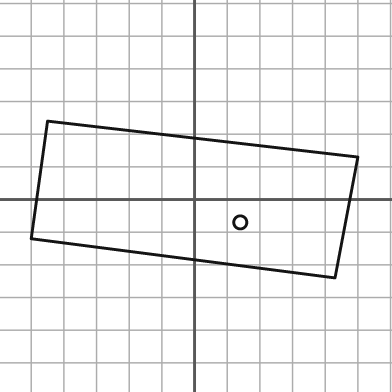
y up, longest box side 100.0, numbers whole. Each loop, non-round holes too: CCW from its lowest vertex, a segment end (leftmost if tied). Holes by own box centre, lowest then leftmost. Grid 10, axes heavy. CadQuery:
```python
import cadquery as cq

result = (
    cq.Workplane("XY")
    .moveTo(43.0, -24.0)
    .lineTo(50.0, 13.0)
    .lineTo(-45.0, 24.0)
    .lineTo(-50.0, -12.0)
    .close()
    .moveTo(14.0, -7.0)
    .circle(2.0)
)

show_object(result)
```